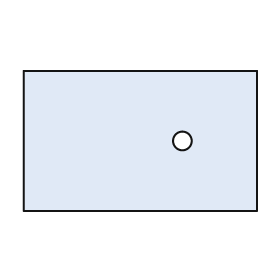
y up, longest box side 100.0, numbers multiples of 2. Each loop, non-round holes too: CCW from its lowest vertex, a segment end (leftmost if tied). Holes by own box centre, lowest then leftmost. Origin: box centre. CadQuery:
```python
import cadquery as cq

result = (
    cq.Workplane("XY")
    .moveTo(-50.0, -30.0)
    .lineTo(50.0, -30.0)
    .lineTo(50.0, 30.0)
    .lineTo(-50.0, 30.0)
    .close()
    .moveTo(18.0, 0.0)
    .circle(4.0)
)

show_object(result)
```